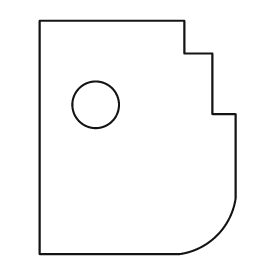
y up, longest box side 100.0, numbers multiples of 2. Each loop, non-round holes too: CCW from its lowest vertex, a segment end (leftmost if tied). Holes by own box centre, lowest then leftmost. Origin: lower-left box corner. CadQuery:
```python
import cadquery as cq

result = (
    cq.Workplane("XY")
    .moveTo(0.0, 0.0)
    .lineTo(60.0, 0.0)
    .threePointArc((76.0, 8.0), (84.0, 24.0))
    .lineTo(84.0, 60.0)
    .lineTo(74.0, 60.0)
    .lineTo(74.0, 86.0)
    .lineTo(62.0, 86.0)
    .lineTo(62.0, 100.0)
    .lineTo(0.0, 100.0)
    .close()
    .moveTo(24.0, 64.0)
    .circle(10.0)
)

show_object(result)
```